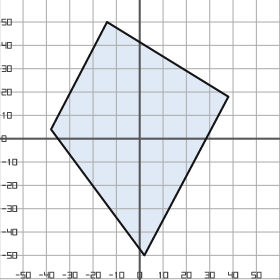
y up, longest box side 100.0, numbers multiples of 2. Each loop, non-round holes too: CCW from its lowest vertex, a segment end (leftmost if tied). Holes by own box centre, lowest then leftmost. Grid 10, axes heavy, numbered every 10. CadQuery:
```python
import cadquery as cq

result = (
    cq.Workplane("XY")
    .moveTo(2.0, -50.0)
    .lineTo(38.0, 18.0)
    .lineTo(-14.0, 50.0)
    .lineTo(-38.0, 4.0)
    .close()
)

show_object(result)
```